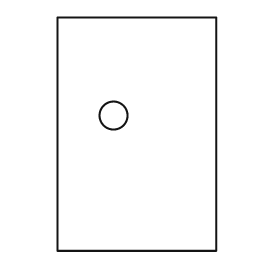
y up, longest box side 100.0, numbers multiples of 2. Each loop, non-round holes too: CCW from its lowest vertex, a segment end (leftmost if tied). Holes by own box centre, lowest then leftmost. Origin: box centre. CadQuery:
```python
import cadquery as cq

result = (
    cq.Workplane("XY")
    .moveTo(-34.0, -50.0)
    .lineTo(34.0, -50.0)
    .lineTo(34.0, 50.0)
    .lineTo(-34.0, 50.0)
    .close()
    .moveTo(-10.0, 8.0)
    .circle(6.0)
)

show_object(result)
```